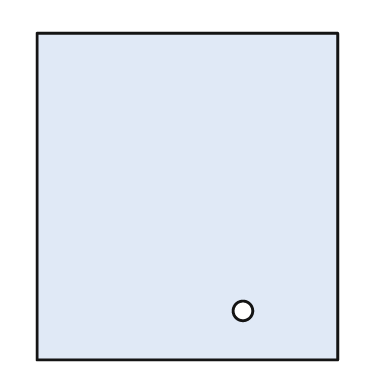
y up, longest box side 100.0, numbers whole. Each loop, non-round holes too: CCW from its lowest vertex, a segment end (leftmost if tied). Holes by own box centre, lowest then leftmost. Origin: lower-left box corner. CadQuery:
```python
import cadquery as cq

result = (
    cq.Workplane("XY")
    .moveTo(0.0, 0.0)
    .lineTo(92.0, 0.0)
    .lineTo(92.0, 100.0)
    .lineTo(0.0, 100.0)
    .close()
    .moveTo(63.0, 15.0)
    .circle(3.0)
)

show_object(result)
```